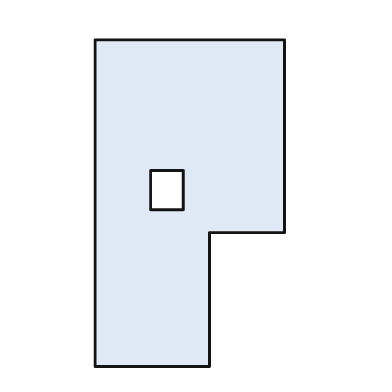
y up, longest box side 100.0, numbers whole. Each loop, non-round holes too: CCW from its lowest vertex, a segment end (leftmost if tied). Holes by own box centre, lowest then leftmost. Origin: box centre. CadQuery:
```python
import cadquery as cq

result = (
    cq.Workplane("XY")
    .moveTo(-29.0, -50.0)
    .lineTo(6.0, -50.0)
    .lineTo(6.0, -9.0)
    .lineTo(29.0, -9.0)
    .lineTo(29.0, 50.0)
    .lineTo(-29.0, 50.0)
    .close()
    .moveTo(-12.0, -2.0)
    .lineTo(-2.0, -2.0)
    .lineTo(-2.0, 10.0)
    .lineTo(-12.0, 10.0)
    .close()
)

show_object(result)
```